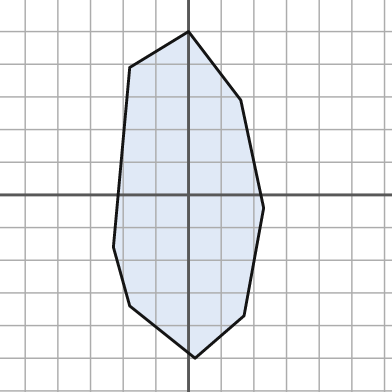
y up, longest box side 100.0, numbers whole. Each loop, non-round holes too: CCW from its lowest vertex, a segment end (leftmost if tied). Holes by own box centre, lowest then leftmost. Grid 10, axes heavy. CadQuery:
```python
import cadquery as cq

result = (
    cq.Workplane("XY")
    .moveTo(2.0, -50.0)
    .lineTo(17.0, -37.0)
    .lineTo(23.0, -4.0)
    .lineTo(16.0, 29.0)
    .lineTo(0.0, 50.0)
    .lineTo(-18.0, 39.0)
    .lineTo(-23.0, -16.0)
    .lineTo(-18.0, -34.0)
    .close()
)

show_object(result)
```